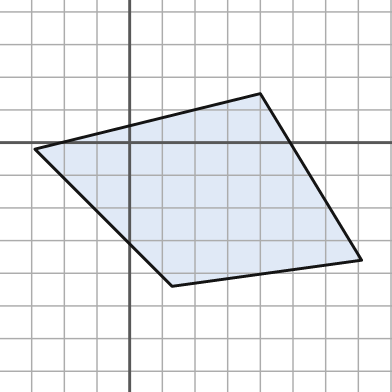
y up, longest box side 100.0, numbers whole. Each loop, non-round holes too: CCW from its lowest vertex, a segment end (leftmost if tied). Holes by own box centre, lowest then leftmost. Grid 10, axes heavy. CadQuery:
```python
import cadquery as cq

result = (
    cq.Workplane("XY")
    .moveTo(13.0, -44.0)
    .lineTo(71.0, -36.0)
    .lineTo(40.0, 15.0)
    .lineTo(-29.0, -2.0)
    .close()
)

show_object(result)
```